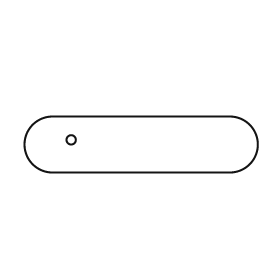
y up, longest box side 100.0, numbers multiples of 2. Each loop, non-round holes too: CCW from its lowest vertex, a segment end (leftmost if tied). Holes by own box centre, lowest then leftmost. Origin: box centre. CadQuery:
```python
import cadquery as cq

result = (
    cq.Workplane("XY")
    .moveTo(-38.0, -12.0)
    .lineTo(38.0, -12.0)
    .threePointArc((50.0, 0.0), (38.0, 12.0))
    .lineTo(-38.0, 12.0)
    .threePointArc((-50.0, 0.0), (-38.0, -12.0))
    .close()
    .moveTo(-30.0, 2.0)
    .circle(2.0)
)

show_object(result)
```